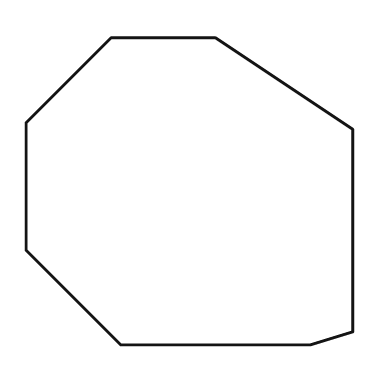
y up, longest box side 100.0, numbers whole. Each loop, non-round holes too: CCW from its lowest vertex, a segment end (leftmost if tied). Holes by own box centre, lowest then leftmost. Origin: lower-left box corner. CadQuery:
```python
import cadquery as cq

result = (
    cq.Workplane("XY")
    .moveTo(29.0, 0.0)
    .lineTo(87.0, 0.0)
    .lineTo(100.0, 4.0)
    .lineTo(100.0, 66.0)
    .lineTo(58.0, 94.0)
    .lineTo(26.0, 94.0)
    .lineTo(0.0, 68.0)
    .lineTo(0.0, 29.0)
    .close()
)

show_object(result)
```